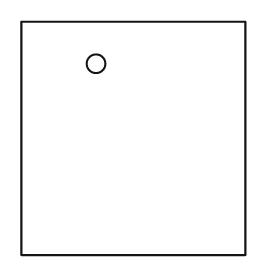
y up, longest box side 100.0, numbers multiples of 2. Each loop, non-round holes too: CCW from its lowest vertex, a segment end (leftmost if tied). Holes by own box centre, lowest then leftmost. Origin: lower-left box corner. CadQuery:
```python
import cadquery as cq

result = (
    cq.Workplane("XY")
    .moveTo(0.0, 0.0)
    .lineTo(96.0, 0.0)
    .lineTo(96.0, 100.0)
    .lineTo(0.0, 100.0)
    .close()
    .moveTo(32.0, 82.0)
    .circle(4.0)
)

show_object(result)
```